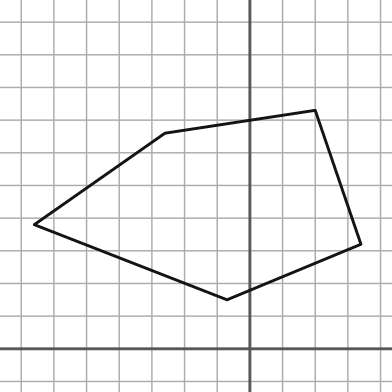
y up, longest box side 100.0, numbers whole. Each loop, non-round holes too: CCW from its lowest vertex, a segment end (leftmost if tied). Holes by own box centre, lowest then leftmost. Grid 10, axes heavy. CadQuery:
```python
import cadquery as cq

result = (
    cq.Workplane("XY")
    .moveTo(-7.0, 15.0)
    .lineTo(34.0, 32.0)
    .lineTo(20.0, 73.0)
    .lineTo(-26.0, 66.0)
    .lineTo(-66.0, 38.0)
    .close()
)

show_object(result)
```